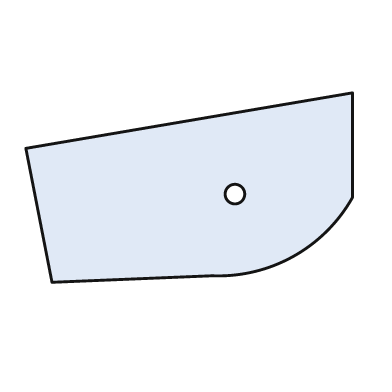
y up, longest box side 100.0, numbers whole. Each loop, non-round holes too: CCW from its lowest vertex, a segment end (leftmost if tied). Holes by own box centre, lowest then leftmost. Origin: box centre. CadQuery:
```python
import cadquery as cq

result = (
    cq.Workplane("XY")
    .moveTo(-42.0, -29.0)
    .lineTo(7.0, -27.0)
    .threePointArc((32.0, -21.0), (50.0, -3.0))
    .lineTo(50.0, 29.0)
    .lineTo(-50.0, 12.0)
    .close()
    .moveTo(14.0, -2.0)
    .circle(3.0)
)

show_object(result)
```